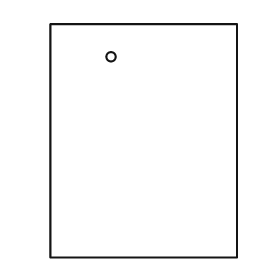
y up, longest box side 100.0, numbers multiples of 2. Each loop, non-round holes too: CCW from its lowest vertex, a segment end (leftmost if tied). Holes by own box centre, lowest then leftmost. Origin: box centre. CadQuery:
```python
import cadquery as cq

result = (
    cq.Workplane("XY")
    .moveTo(-40.0, -50.0)
    .lineTo(40.0, -50.0)
    .lineTo(40.0, 50.0)
    .lineTo(-40.0, 50.0)
    .close()
    .moveTo(-14.0, 36.0)
    .circle(2.0)
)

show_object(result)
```